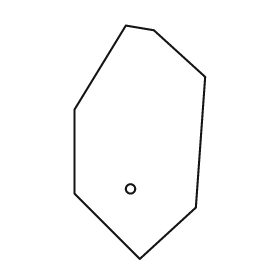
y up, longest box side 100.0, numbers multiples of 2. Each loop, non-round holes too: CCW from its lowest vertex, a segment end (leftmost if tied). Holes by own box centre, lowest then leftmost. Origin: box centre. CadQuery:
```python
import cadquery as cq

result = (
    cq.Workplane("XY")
    .moveTo(0.0, -50.0)
    .lineTo(24.0, -28.0)
    .lineTo(28.0, 28.0)
    .lineTo(6.0, 48.0)
    .lineTo(-6.0, 50.0)
    .lineTo(-28.0, 14.0)
    .lineTo(-28.0, -22.0)
    .close()
    .moveTo(-4.0, -20.0)
    .circle(2.0)
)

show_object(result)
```